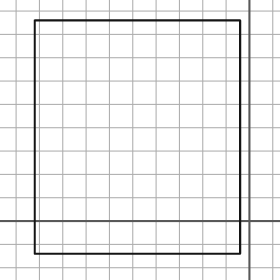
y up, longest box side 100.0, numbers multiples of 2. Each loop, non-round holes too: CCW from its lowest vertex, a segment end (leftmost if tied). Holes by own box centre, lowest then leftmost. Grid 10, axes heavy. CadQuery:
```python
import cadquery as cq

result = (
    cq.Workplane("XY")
    .moveTo(-92.0, -14.0)
    .lineTo(-4.0, -14.0)
    .lineTo(-4.0, 86.0)
    .lineTo(-92.0, 86.0)
    .close()
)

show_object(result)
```